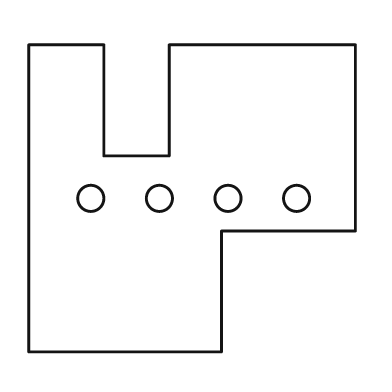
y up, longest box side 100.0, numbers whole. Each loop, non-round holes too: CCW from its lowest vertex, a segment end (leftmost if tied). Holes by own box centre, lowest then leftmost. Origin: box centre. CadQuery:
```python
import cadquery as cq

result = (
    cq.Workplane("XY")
    .moveTo(-50.0, -47.0)
    .lineTo(9.0, -47.0)
    .lineTo(9.0, -10.0)
    .lineTo(50.0, -10.0)
    .lineTo(50.0, 47.0)
    .lineTo(-7.0, 47.0)
    .lineTo(-7.0, 13.0)
    .lineTo(-27.0, 13.0)
    .lineTo(-27.0, 47.0)
    .lineTo(-50.0, 47.0)
    .close()
    .moveTo(-31.0, 0.0)
    .circle(4.0)
    .moveTo(-10.0, 0.0)
    .circle(4.0)
    .moveTo(11.0, 0.0)
    .circle(4.0)
    .moveTo(32.0, 0.0)
    .circle(4.0)
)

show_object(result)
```